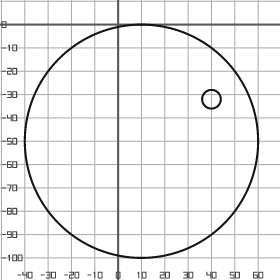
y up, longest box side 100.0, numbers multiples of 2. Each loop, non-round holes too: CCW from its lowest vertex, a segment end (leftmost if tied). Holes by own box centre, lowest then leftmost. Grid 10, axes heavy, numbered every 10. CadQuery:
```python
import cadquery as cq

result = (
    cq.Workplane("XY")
    .moveTo(10.0, -50.0)
    .circle(50.0)
    .moveTo(40.0, -32.0)
    .circle(4.0)
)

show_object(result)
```